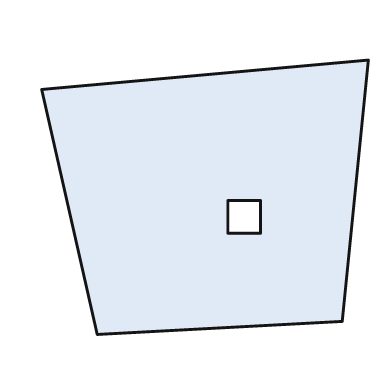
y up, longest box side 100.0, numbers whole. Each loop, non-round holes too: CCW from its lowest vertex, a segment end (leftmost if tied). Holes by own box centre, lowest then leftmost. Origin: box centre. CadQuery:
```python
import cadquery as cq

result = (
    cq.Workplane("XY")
    .moveTo(-33.0, -42.0)
    .lineTo(42.0, -38.0)
    .lineTo(50.0, 42.0)
    .lineTo(-50.0, 33.0)
    .close()
    .moveTo(7.0, -11.0)
    .lineTo(17.0, -11.0)
    .lineTo(17.0, -1.0)
    .lineTo(7.0, -1.0)
    .close()
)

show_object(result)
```